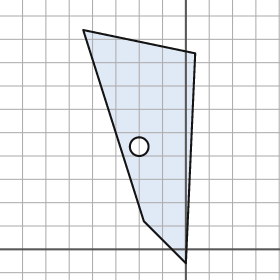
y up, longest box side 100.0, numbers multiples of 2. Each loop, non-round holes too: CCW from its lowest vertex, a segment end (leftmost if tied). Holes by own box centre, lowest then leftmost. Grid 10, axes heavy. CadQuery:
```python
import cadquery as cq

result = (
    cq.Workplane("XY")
    .moveTo(0.0, -6.0)
    .lineTo(4.0, 84.0)
    .lineTo(-44.0, 94.0)
    .lineTo(-18.0, 12.0)
    .close()
    .moveTo(-20.0, 44.0)
    .circle(4.0)
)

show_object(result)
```